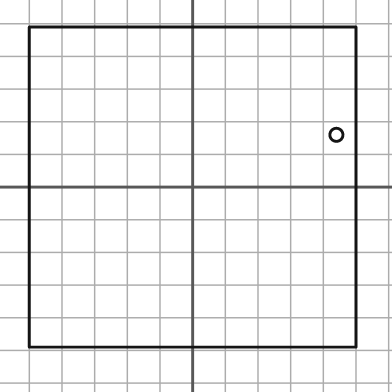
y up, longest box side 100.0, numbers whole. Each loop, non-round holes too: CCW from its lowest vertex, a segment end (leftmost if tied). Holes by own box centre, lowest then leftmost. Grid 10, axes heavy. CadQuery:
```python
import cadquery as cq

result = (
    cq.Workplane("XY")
    .moveTo(-50.0, -49.0)
    .lineTo(50.0, -49.0)
    .lineTo(50.0, 49.0)
    .lineTo(-50.0, 49.0)
    .close()
    .moveTo(44.0, 16.0)
    .circle(2.0)
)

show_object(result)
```